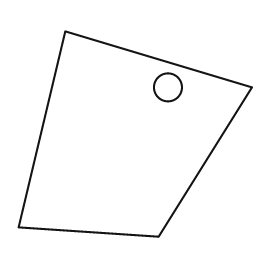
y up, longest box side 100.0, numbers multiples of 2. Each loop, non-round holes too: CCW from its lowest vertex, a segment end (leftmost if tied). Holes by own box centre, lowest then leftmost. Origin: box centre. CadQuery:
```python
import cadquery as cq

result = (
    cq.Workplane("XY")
    .moveTo(10.0, -44.0)
    .lineTo(50.0, 20.0)
    .lineTo(-30.0, 44.0)
    .lineTo(-50.0, -40.0)
    .close()
    .moveTo(14.0, 20.0)
    .circle(6.0)
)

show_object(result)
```